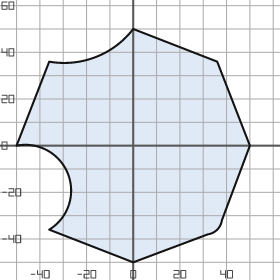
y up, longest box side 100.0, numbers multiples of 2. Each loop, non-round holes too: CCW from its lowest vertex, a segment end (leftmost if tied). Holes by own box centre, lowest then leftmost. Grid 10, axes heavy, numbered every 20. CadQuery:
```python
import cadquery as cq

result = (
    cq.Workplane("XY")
    .moveTo(0.0, -50.0)
    .lineTo(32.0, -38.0)
    .threePointArc((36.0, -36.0), (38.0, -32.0))
    .lineTo(50.0, 0.0)
    .lineTo(36.0, 36.0)
    .lineTo(0.0, 50.0)
    .threePointArc((-16.0, 38.0), (-36.0, 36.0))
    .lineTo(-50.0, 0.0)
    .threePointArc((-28.0, -12.0), (-36.0, -36.0))
    .close()
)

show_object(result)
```